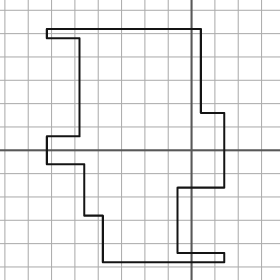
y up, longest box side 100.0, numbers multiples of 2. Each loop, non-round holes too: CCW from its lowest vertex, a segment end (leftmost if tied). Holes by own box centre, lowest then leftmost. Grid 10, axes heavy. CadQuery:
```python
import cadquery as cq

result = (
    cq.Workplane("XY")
    .moveTo(-38.0, -48.0)
    .lineTo(14.0, -48.0)
    .lineTo(14.0, -44.0)
    .lineTo(-6.0, -44.0)
    .lineTo(-6.0, -16.0)
    .lineTo(14.0, -16.0)
    .lineTo(14.0, 16.0)
    .lineTo(4.0, 16.0)
    .lineTo(4.0, 52.0)
    .lineTo(-62.0, 52.0)
    .lineTo(-62.0, 48.0)
    .lineTo(-48.0, 48.0)
    .lineTo(-48.0, 6.0)
    .lineTo(-62.0, 6.0)
    .lineTo(-62.0, -6.0)
    .lineTo(-46.0, -6.0)
    .lineTo(-46.0, -28.0)
    .lineTo(-38.0, -28.0)
    .close()
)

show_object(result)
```